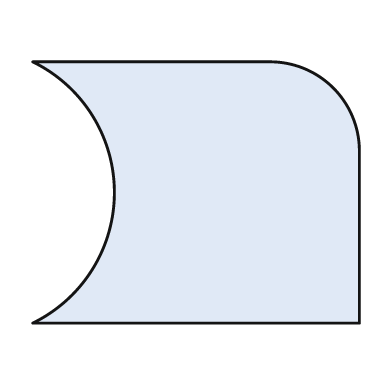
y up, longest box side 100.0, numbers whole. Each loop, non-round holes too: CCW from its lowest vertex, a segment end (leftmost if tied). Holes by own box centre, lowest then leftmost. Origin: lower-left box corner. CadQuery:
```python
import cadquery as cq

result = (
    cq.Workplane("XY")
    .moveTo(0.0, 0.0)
    .lineTo(100.0, 0.0)
    .lineTo(100.0, 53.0)
    .threePointArc((92.0, 72.0), (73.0, 80.0))
    .lineTo(0.0, 80.0)
    .threePointArc((25.0, 40.0), (0.0, 0.0))
    .close()
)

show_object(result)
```